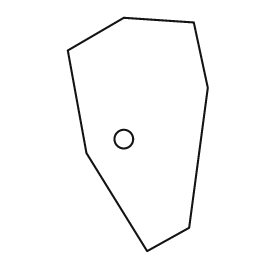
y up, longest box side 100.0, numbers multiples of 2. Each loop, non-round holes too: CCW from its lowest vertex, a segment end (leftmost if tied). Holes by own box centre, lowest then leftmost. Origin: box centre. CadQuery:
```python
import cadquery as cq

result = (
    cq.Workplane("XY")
    .moveTo(4.0, -50.0)
    .lineTo(22.0, -40.0)
    .lineTo(30.0, 20.0)
    .lineTo(24.0, 48.0)
    .lineTo(-6.0, 50.0)
    .lineTo(-30.0, 36.0)
    .lineTo(-22.0, -8.0)
    .close()
    .moveTo(-6.0, -2.0)
    .circle(4.0)
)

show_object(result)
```